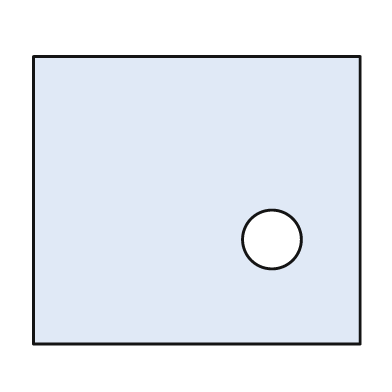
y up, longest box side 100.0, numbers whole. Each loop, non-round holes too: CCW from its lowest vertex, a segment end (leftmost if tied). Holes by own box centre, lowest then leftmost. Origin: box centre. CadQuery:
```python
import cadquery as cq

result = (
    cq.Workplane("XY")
    .moveTo(-50.0, -44.0)
    .lineTo(50.0, -44.0)
    .lineTo(50.0, 44.0)
    .lineTo(-50.0, 44.0)
    .close()
    .moveTo(23.0, -12.0)
    .circle(9.0)
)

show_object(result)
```